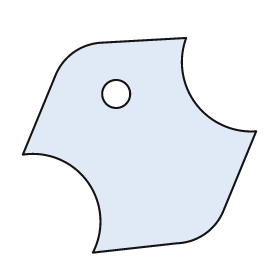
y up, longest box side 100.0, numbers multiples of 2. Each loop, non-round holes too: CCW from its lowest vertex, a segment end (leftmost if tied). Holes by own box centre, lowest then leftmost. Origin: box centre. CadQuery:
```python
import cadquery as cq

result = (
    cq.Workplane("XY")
    .moveTo(-20.0, -46.0)
    .lineTo(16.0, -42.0)
    .threePointArc((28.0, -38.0), (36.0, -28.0))
    .lineTo(50.0, 6.0)
    .threePointArc((24.0, 18.0), (20.0, 46.0))
    .lineTo(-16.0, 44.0)
    .threePointArc((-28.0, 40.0), (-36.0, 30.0))
    .lineTo(-50.0, -4.0)
    .threePointArc((-22.0, -16.0), (-20.0, -46.0))
    .close()
    .moveTo(-10.0, 22.0)
    .circle(6.0)
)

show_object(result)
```